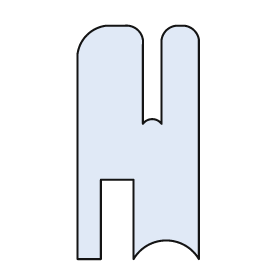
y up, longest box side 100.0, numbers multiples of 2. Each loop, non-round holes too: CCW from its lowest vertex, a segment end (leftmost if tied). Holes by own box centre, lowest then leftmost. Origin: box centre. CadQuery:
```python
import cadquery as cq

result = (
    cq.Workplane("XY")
    .moveTo(-26.0, -50.0)
    .lineTo(-16.0, -50.0)
    .lineTo(-16.0, -16.0)
    .lineTo(-2.0, -16.0)
    .lineTo(-2.0, -50.0)
    .threePointArc((12.0, -42.0), (26.0, -50.0))
    .lineTo(26.0, 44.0)
    .threePointArc((24.0, 48.0), (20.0, 50.0))
    .lineTo(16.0, 50.0)
    .threePointArc((12.0, 48.0), (10.0, 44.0))
    .lineTo(10.0, 8.0)
    .threePointArc((6.0, 10.0), (2.0, 8.0))
    .lineTo(2.0, 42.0)
    .threePointArc((0.0, 48.0), (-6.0, 50.0))
    .lineTo(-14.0, 50.0)
    .threePointArc((-22.0, 46.0), (-26.0, 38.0))
    .close()
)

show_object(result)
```